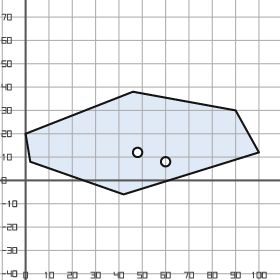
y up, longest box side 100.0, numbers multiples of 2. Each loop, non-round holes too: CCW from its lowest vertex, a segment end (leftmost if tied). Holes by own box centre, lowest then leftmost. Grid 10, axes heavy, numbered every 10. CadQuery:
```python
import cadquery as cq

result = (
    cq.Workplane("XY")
    .moveTo(42.0, -6.0)
    .lineTo(100.0, 12.0)
    .lineTo(90.0, 30.0)
    .lineTo(46.0, 38.0)
    .lineTo(0.0, 20.0)
    .lineTo(2.0, 8.0)
    .close()
    .moveTo(60.0, 8.0)
    .circle(2.0)
    .moveTo(48.0, 12.0)
    .circle(2.0)
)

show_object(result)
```